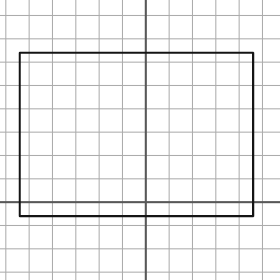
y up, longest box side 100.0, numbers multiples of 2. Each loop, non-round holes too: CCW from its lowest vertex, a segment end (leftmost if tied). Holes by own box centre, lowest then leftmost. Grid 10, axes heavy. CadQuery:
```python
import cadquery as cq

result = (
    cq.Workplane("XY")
    .moveTo(-54.0, -6.0)
    .lineTo(46.0, -6.0)
    .lineTo(46.0, 64.0)
    .lineTo(-54.0, 64.0)
    .close()
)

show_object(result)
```